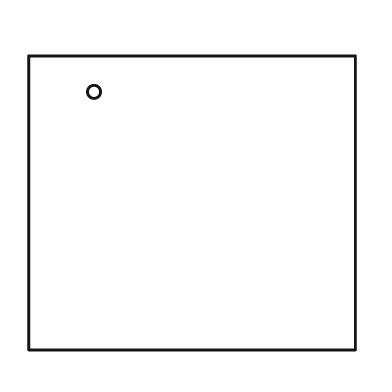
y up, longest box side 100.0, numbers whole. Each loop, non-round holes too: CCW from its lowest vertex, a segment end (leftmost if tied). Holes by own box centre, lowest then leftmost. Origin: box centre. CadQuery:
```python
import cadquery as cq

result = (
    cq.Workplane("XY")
    .moveTo(-50.0, -45.0)
    .lineTo(50.0, -45.0)
    .lineTo(50.0, 45.0)
    .lineTo(-50.0, 45.0)
    .close()
    .moveTo(-30.0, 34.0)
    .circle(2.0)
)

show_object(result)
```